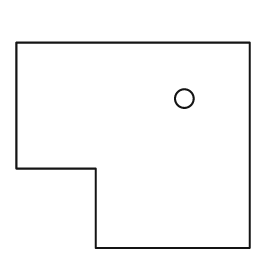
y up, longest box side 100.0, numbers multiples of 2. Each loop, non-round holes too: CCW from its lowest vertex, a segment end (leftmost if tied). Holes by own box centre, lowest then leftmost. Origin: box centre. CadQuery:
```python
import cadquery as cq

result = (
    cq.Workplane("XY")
    .moveTo(-16.0, -44.0)
    .lineTo(50.0, -44.0)
    .lineTo(50.0, 44.0)
    .lineTo(-50.0, 44.0)
    .lineTo(-50.0, -10.0)
    .lineTo(-16.0, -10.0)
    .close()
    .moveTo(22.0, 20.0)
    .circle(4.0)
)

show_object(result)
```